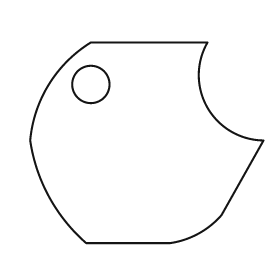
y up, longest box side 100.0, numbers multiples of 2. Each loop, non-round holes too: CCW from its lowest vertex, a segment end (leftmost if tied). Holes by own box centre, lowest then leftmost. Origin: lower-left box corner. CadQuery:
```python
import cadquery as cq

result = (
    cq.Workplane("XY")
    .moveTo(24.0, 0.0)
    .lineTo(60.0, 0.0)
    .threePointArc((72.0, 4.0), (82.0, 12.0))
    .lineTo(100.0, 44.0)
    .threePointArc((76.0, 58.0), (76.0, 86.0))
    .lineTo(26.0, 86.0)
    .threePointArc((8.0, 68.0), (0.0, 44.0))
    .threePointArc((8.0, 20.0), (24.0, 0.0))
    .close()
    .moveTo(26.0, 68.0)
    .circle(8.0)
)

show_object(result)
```